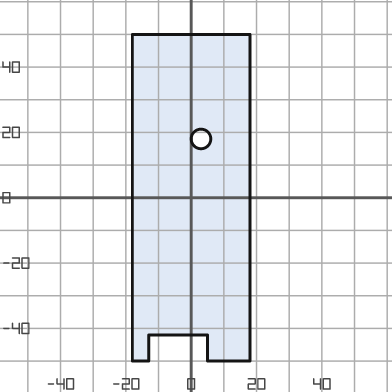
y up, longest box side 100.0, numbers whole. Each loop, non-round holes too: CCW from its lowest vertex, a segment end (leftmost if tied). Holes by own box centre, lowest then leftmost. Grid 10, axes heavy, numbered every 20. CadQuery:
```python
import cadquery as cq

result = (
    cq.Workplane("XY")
    .moveTo(-18.0, -50.0)
    .lineTo(-13.0, -50.0)
    .lineTo(-13.0, -42.0)
    .lineTo(5.0, -42.0)
    .lineTo(5.0, -50.0)
    .lineTo(18.0, -50.0)
    .lineTo(18.0, 50.0)
    .lineTo(-18.0, 50.0)
    .close()
    .moveTo(3.0, 18.0)
    .circle(3.0)
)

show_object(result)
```